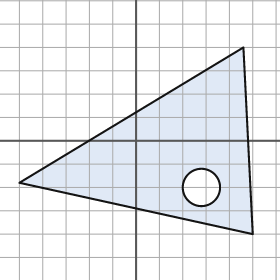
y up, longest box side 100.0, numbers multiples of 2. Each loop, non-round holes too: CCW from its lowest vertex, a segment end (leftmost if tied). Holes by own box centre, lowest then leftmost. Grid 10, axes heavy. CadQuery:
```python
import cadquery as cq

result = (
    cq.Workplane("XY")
    .moveTo(50.0, -40.0)
    .lineTo(46.0, 40.0)
    .lineTo(-50.0, -18.0)
    .close()
    .moveTo(28.0, -20.0)
    .circle(8.0)
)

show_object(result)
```